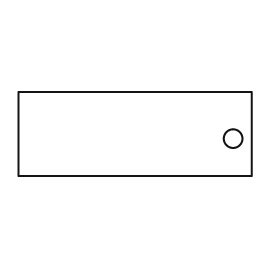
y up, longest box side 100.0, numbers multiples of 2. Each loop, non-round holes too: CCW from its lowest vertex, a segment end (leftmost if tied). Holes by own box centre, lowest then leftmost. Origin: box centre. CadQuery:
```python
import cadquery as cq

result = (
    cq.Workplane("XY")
    .moveTo(-50.0, -18.0)
    .lineTo(50.0, -18.0)
    .lineTo(50.0, 18.0)
    .lineTo(-50.0, 18.0)
    .close()
    .moveTo(42.0, -2.0)
    .circle(4.0)
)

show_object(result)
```